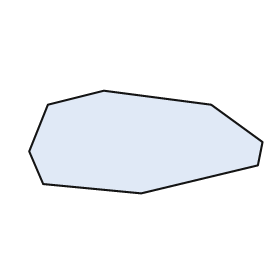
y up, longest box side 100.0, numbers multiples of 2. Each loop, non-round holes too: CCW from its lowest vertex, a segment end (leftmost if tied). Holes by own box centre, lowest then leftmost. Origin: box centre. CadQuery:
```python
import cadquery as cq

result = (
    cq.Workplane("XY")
    .moveTo(-2.0, -22.0)
    .lineTo(48.0, -10.0)
    .lineTo(50.0, 0.0)
    .lineTo(28.0, 16.0)
    .lineTo(-18.0, 22.0)
    .lineTo(-42.0, 16.0)
    .lineTo(-50.0, -4.0)
    .lineTo(-44.0, -18.0)
    .close()
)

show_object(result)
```